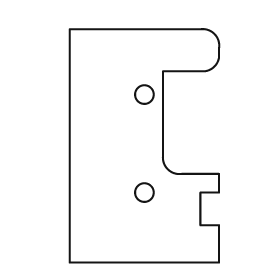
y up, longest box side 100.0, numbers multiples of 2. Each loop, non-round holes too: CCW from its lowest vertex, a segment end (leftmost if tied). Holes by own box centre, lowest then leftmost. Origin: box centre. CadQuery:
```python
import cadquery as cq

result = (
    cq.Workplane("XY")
    .moveTo(-32.0, -50.0)
    .lineTo(32.0, -50.0)
    .lineTo(32.0, -34.0)
    .lineTo(24.0, -34.0)
    .lineTo(24.0, -20.0)
    .lineTo(32.0, -20.0)
    .lineTo(32.0, -12.0)
    .lineTo(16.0, -12.0)
    .threePointArc((10.0, -10.0), (8.0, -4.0))
    .lineTo(8.0, 32.0)
    .lineTo(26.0, 32.0)
    .threePointArc((30.0, 34.0), (32.0, 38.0))
    .lineTo(32.0, 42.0)
    .threePointArc((30.0, 48.0), (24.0, 50.0))
    .lineTo(-32.0, 50.0)
    .close()
    .moveTo(0.0, -20.0)
    .circle(4.0)
    .moveTo(0.0, 22.0)
    .circle(4.0)
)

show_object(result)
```